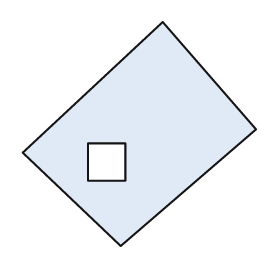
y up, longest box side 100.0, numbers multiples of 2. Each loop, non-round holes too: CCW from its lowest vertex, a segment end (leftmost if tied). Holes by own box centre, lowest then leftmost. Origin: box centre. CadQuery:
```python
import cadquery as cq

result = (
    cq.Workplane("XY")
    .moveTo(-8.0, -48.0)
    .lineTo(50.0, 2.0)
    .lineTo(10.0, 48.0)
    .lineTo(-50.0, -8.0)
    .close()
    .moveTo(-22.0, -20.0)
    .lineTo(-6.0, -20.0)
    .lineTo(-6.0, -4.0)
    .lineTo(-22.0, -4.0)
    .close()
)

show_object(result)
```